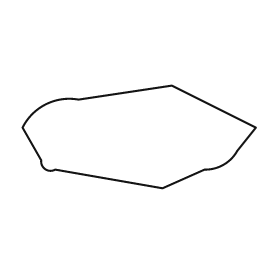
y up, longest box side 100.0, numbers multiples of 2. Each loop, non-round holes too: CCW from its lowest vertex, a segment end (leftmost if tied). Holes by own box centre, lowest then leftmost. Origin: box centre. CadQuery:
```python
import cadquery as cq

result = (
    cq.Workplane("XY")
    .moveTo(10.0, -22.0)
    .lineTo(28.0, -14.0)
    .threePointArc((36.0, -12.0), (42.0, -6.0))
    .lineTo(50.0, 4.0)
    .lineTo(14.0, 22.0)
    .lineTo(-26.0, 16.0)
    .threePointArc((-40.0, 14.0), (-50.0, 4.0))
    .lineTo(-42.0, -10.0)
    .threePointArc((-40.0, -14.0), (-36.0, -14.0))
    .close()
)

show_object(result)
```